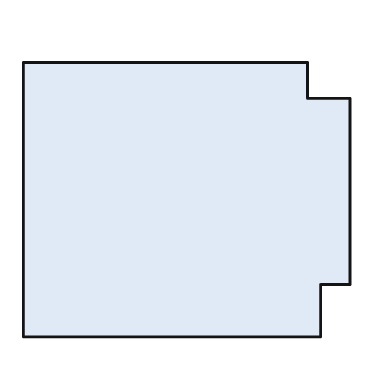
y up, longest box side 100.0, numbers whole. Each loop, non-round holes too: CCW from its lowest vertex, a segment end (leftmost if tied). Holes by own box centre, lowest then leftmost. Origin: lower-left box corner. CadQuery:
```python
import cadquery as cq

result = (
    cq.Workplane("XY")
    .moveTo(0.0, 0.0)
    .lineTo(91.0, 0.0)
    .lineTo(91.0, 16.0)
    .lineTo(100.0, 16.0)
    .lineTo(100.0, 73.0)
    .lineTo(87.0, 73.0)
    .lineTo(87.0, 84.0)
    .lineTo(0.0, 84.0)
    .close()
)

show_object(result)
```